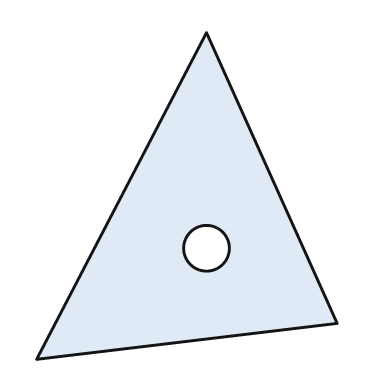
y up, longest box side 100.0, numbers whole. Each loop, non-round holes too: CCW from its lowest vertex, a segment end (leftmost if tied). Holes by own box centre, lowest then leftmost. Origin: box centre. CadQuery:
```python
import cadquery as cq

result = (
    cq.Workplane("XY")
    .moveTo(-46.0, -50.0)
    .lineTo(46.0, -39.0)
    .lineTo(6.0, 50.0)
    .close()
    .moveTo(6.0, -16.0)
    .circle(7.0)
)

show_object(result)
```